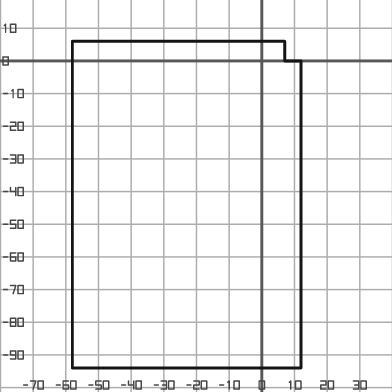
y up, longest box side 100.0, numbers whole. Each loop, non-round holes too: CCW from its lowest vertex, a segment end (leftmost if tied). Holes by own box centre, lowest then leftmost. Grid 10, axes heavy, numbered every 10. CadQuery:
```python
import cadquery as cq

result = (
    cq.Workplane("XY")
    .moveTo(-58.0, -94.0)
    .lineTo(12.0, -94.0)
    .lineTo(12.0, 0.0)
    .lineTo(7.0, 0.0)
    .lineTo(7.0, 6.0)
    .lineTo(-58.0, 6.0)
    .close()
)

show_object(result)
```